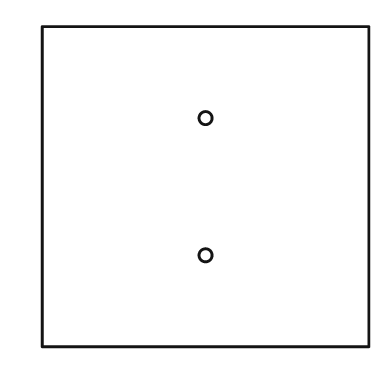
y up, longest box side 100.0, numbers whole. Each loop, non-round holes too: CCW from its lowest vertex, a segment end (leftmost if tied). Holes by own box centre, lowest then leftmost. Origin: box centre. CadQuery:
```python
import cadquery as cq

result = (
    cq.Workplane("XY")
    .moveTo(-50.0, -49.0)
    .lineTo(50.0, -49.0)
    .lineTo(50.0, 49.0)
    .lineTo(-50.0, 49.0)
    .close()
    .moveTo(0.0, -21.0)
    .circle(2.0)
    .moveTo(0.0, 21.0)
    .circle(2.0)
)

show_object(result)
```